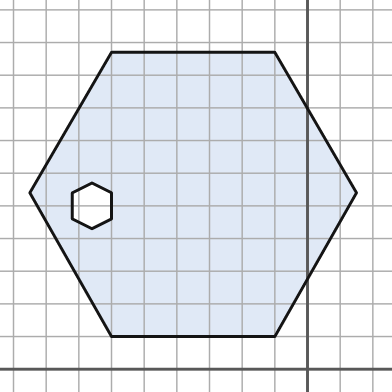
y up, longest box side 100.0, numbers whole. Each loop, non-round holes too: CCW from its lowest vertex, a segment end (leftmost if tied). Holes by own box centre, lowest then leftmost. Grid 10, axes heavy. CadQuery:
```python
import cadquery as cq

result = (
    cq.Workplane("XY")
    .moveTo(-60.0, 10.0)
    .lineTo(-10.0, 10.0)
    .lineTo(15.0, 54.0)
    .lineTo(-10.0, 97.0)
    .lineTo(-60.0, 97.0)
    .lineTo(-85.0, 54.0)
    .close()
    .moveTo(-66.0, 43.0)
    .lineTo(-60.0, 46.0)
    .lineTo(-60.0, 54.0)
    .lineTo(-66.0, 57.0)
    .lineTo(-72.0, 54.0)
    .lineTo(-72.0, 46.0)
    .close()
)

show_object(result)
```